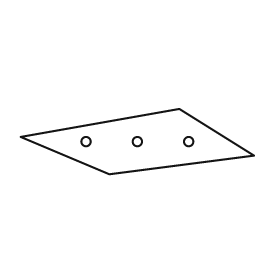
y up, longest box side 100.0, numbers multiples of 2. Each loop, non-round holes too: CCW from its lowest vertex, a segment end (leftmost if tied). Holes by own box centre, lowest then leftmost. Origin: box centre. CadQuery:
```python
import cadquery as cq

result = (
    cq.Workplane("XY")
    .moveTo(-12.0, -14.0)
    .lineTo(50.0, -6.0)
    .lineTo(18.0, 14.0)
    .lineTo(-50.0, 2.0)
    .close()
    .moveTo(-22.0, 0.0)
    .circle(2.0)
    .moveTo(0.0, 0.0)
    .circle(2.0)
    .moveTo(22.0, 0.0)
    .circle(2.0)
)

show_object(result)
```